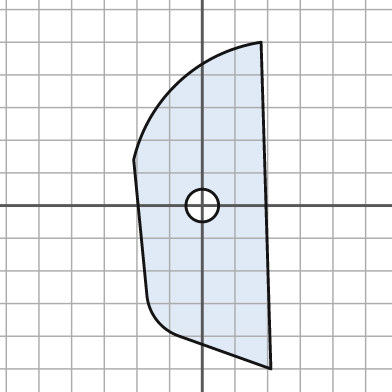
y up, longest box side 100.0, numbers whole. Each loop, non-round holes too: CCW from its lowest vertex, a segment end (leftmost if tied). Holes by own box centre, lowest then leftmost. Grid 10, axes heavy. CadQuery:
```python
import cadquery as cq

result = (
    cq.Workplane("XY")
    .moveTo(21.0, -50.0)
    .lineTo(18.0, 50.0)
    .threePointArc((-7.0, 38.0), (-21.0, 14.0))
    .lineTo(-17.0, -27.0)
    .threePointArc((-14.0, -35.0), (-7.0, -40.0))
    .close()
    .moveTo(0.0, 0.0)
    .circle(5.0)
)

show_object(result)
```